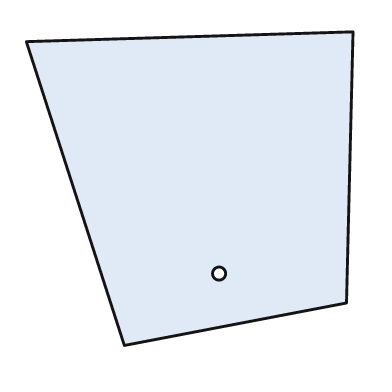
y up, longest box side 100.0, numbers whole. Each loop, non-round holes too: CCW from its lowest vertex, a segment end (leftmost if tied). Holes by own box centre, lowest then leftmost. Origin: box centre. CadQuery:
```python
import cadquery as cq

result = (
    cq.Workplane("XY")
    .moveTo(-20.0, -48.0)
    .lineTo(48.0, -35.0)
    .lineTo(50.0, 48.0)
    .lineTo(-50.0, 45.0)
    .close()
    .moveTo(9.0, -26.0)
    .circle(2.0)
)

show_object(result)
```